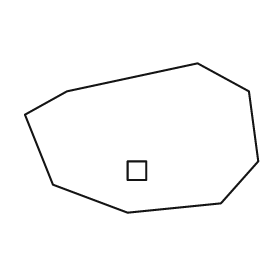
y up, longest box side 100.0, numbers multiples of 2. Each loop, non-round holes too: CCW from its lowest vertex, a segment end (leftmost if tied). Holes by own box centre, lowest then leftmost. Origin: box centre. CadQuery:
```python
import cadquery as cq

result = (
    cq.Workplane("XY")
    .moveTo(-6.0, -32.0)
    .lineTo(34.0, -28.0)
    .lineTo(50.0, -10.0)
    .lineTo(46.0, 20.0)
    .lineTo(24.0, 32.0)
    .lineTo(-32.0, 20.0)
    .lineTo(-50.0, 10.0)
    .lineTo(-38.0, -20.0)
    .close()
    .moveTo(-6.0, -18.0)
    .lineTo(2.0, -18.0)
    .lineTo(2.0, -10.0)
    .lineTo(-6.0, -10.0)
    .close()
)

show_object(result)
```